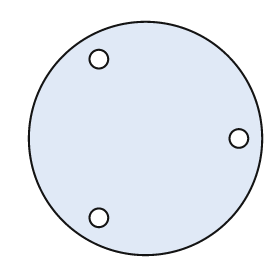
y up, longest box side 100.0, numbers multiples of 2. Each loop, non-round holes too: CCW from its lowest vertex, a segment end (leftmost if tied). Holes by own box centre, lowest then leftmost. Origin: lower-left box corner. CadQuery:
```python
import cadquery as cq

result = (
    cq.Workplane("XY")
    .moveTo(50.0, 50.0)
    .circle(50.0)
    .moveTo(30.0, 16.0)
    .circle(4.0)
    .moveTo(90.0, 50.0)
    .circle(4.0)
    .moveTo(30.0, 84.0)
    .circle(4.0)
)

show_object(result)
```